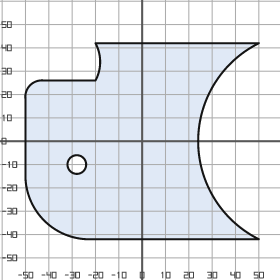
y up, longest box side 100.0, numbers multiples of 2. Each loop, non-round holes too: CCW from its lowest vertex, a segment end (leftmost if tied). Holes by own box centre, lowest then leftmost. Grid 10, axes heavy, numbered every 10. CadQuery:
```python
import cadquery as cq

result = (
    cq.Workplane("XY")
    .moveTo(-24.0, -42.0)
    .lineTo(50.0, -42.0)
    .threePointArc((24.0, 0.0), (50.0, 42.0))
    .lineTo(-20.0, 42.0)
    .threePointArc((-18.0, 34.0), (-20.0, 26.0))
    .lineTo(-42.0, 26.0)
    .threePointArc((-48.0, 24.0), (-50.0, 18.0))
    .lineTo(-50.0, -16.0)
    .threePointArc((-42.0, -34.0), (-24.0, -42.0))
    .close()
    .moveTo(-28.0, -10.0)
    .circle(4.0)
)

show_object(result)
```